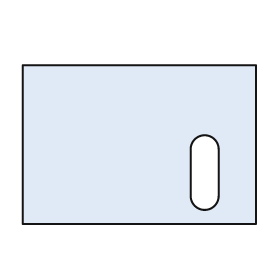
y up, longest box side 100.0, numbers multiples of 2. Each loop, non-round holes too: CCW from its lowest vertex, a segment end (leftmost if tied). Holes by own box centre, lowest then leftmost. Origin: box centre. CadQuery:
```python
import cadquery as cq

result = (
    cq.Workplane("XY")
    .moveTo(-50.0, -34.0)
    .lineTo(50.0, -34.0)
    .lineTo(50.0, 34.0)
    .lineTo(-50.0, 34.0)
    .close()
    .moveTo(22.0, -22.0)
    .threePointArc((28.0, -28.0), (34.0, -22.0))
    .lineTo(34.0, -2.0)
    .threePointArc((28.0, 4.0), (22.0, -2.0))
    .close()
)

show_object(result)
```